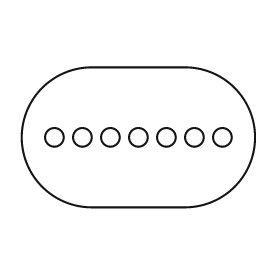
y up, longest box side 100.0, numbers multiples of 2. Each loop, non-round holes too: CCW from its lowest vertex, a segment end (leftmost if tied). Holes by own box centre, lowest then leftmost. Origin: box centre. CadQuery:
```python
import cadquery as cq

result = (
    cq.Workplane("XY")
    .moveTo(-20.0, -30.0)
    .lineTo(20.0, -30.0)
    .threePointArc((50.0, 0.0), (20.0, 30.0))
    .lineTo(-20.0, 30.0)
    .threePointArc((-50.0, 0.0), (-20.0, -30.0))
    .close()
    .moveTo(-36.0, 0.0)
    .circle(4.0)
    .moveTo(-24.0, 0.0)
    .circle(4.0)
    .moveTo(-12.0, 0.0)
    .circle(4.0)
    .moveTo(0.0, 0.0)
    .circle(4.0)
    .moveTo(12.0, 0.0)
    .circle(4.0)
    .moveTo(24.0, 0.0)
    .circle(4.0)
    .moveTo(36.0, 0.0)
    .circle(4.0)
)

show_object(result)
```